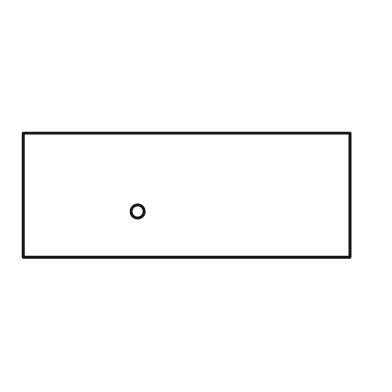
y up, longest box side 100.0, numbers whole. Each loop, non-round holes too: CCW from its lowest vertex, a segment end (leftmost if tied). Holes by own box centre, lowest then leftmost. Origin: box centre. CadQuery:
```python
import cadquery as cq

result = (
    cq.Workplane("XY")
    .moveTo(-50.0, -19.0)
    .lineTo(50.0, -19.0)
    .lineTo(50.0, 19.0)
    .lineTo(-50.0, 19.0)
    .close()
    .moveTo(-15.0, -5.0)
    .circle(2.0)
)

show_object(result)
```